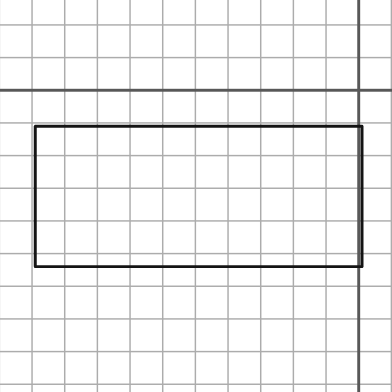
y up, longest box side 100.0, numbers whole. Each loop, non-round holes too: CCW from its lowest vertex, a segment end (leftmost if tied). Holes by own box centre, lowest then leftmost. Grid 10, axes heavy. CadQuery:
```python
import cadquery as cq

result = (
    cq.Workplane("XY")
    .moveTo(-99.0, -54.0)
    .lineTo(1.0, -54.0)
    .lineTo(1.0, -11.0)
    .lineTo(-99.0, -11.0)
    .close()
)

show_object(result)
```